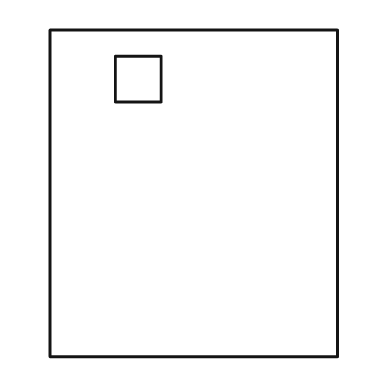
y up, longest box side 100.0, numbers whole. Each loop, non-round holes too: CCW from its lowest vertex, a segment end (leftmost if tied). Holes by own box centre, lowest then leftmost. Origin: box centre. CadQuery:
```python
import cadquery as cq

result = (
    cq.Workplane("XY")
    .moveTo(-44.0, -50.0)
    .lineTo(44.0, -50.0)
    .lineTo(44.0, 50.0)
    .lineTo(-44.0, 50.0)
    .close()
    .moveTo(-24.0, 28.0)
    .lineTo(-10.0, 28.0)
    .lineTo(-10.0, 42.0)
    .lineTo(-24.0, 42.0)
    .close()
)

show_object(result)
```